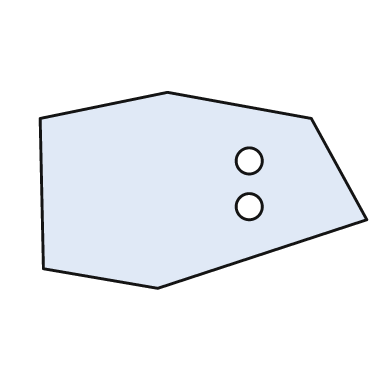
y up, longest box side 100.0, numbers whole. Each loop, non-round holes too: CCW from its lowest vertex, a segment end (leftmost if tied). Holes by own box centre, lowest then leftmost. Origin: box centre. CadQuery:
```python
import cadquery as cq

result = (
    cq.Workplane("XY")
    .moveTo(-14.0, -30.0)
    .lineTo(50.0, -9.0)
    .lineTo(33.0, 22.0)
    .lineTo(-11.0, 30.0)
    .lineTo(-50.0, 22.0)
    .lineTo(-49.0, -24.0)
    .close()
    .moveTo(14.0, -5.0)
    .circle(4.0)
    .moveTo(14.0, 9.0)
    .circle(4.0)
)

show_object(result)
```